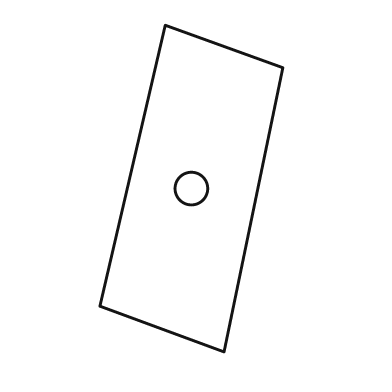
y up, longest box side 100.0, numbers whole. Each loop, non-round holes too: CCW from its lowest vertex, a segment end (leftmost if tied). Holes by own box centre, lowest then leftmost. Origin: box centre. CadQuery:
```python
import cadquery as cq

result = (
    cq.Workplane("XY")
    .moveTo(10.0, -50.0)
    .lineTo(28.0, 37.0)
    .lineTo(-8.0, 50.0)
    .lineTo(-28.0, -36.0)
    .close()
    .moveTo(0.0, 0.0)
    .circle(5.0)
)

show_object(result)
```